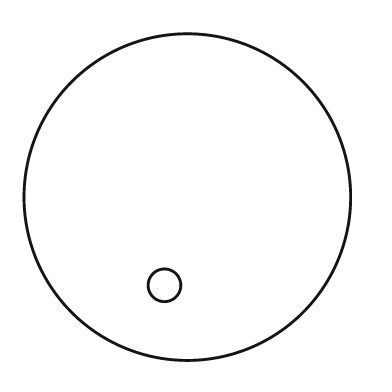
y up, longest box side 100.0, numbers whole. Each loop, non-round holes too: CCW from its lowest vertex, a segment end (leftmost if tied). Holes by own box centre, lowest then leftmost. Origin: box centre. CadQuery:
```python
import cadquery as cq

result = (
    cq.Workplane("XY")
    .moveTo(0.0, 0.0)
    .circle(50.0)
    .moveTo(-7.0, -27.0)
    .circle(5.0)
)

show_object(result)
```